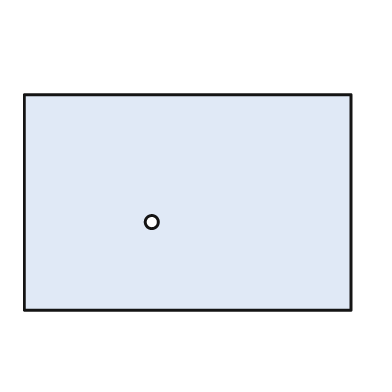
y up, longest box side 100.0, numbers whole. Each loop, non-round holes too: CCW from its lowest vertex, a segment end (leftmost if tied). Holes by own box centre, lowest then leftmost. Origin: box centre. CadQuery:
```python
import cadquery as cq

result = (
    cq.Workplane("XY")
    .moveTo(-50.0, -33.0)
    .lineTo(50.0, -33.0)
    .lineTo(50.0, 33.0)
    .lineTo(-50.0, 33.0)
    .close()
    .moveTo(-11.0, -6.0)
    .circle(2.0)
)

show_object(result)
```